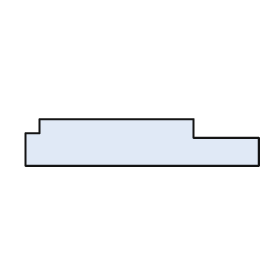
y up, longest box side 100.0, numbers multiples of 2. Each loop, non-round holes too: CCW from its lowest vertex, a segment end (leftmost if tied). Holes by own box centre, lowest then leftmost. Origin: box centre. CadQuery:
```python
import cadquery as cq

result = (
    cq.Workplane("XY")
    .moveTo(-50.0, -10.0)
    .lineTo(50.0, -10.0)
    .lineTo(50.0, 2.0)
    .lineTo(22.0, 2.0)
    .lineTo(22.0, 10.0)
    .lineTo(-44.0, 10.0)
    .lineTo(-44.0, 4.0)
    .lineTo(-50.0, 4.0)
    .close()
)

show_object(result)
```